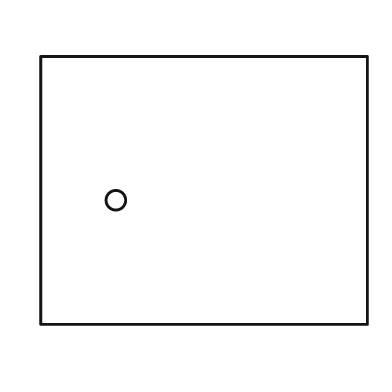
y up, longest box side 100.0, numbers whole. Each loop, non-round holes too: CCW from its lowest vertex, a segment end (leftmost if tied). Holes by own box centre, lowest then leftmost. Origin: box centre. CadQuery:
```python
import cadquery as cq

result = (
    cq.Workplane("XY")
    .moveTo(-50.0, -41.0)
    .lineTo(50.0, -41.0)
    .lineTo(50.0, 41.0)
    .lineTo(-50.0, 41.0)
    .close()
    .moveTo(-27.0, -3.0)
    .circle(3.0)
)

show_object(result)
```